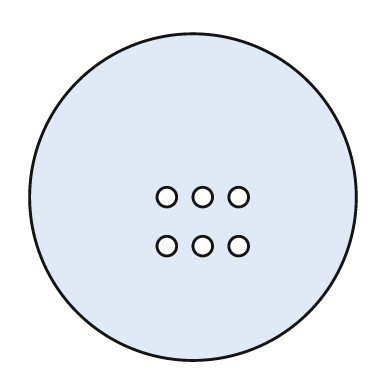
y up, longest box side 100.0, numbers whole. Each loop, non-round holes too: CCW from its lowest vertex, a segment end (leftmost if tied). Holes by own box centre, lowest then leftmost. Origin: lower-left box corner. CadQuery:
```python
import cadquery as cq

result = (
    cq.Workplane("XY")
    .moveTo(50.0, 50.0)
    .circle(50.0)
    .moveTo(42.0, 35.0)
    .circle(3.0)
    .moveTo(53.0, 35.0)
    .circle(3.0)
    .moveTo(64.0, 35.0)
    .circle(3.0)
    .moveTo(42.0, 50.0)
    .circle(3.0)
    .moveTo(53.0, 50.0)
    .circle(3.0)
    .moveTo(64.0, 50.0)
    .circle(3.0)
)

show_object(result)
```